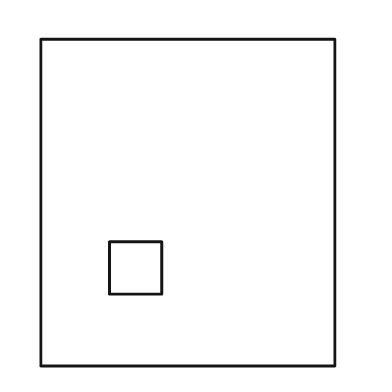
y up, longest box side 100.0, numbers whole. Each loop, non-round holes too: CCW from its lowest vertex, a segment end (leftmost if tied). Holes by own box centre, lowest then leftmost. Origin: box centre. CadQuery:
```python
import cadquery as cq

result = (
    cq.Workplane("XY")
    .moveTo(-45.0, -50.0)
    .lineTo(45.0, -50.0)
    .lineTo(45.0, 50.0)
    .lineTo(-45.0, 50.0)
    .close()
    .moveTo(-24.0, -28.0)
    .lineTo(-8.0, -28.0)
    .lineTo(-8.0, -12.0)
    .lineTo(-24.0, -12.0)
    .close()
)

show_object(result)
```